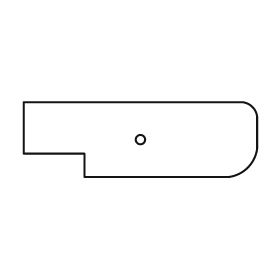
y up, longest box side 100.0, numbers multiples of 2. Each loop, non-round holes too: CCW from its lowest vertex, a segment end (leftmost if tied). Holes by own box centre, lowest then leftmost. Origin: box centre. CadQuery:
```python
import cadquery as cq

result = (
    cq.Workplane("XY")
    .moveTo(-24.0, -16.0)
    .lineTo(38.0, -16.0)
    .threePointArc((46.0, -12.0), (50.0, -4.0))
    .lineTo(50.0, 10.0)
    .threePointArc((48.0, 14.0), (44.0, 16.0))
    .lineTo(-50.0, 16.0)
    .lineTo(-50.0, -6.0)
    .lineTo(-24.0, -6.0)
    .close()
    .moveTo(0.0, 0.0)
    .circle(2.0)
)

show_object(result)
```